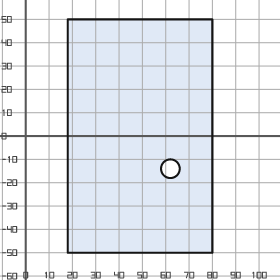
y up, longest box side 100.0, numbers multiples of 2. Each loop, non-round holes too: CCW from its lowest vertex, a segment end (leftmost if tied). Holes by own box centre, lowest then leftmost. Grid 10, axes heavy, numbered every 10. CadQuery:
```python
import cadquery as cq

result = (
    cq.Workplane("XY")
    .moveTo(18.0, -50.0)
    .lineTo(80.0, -50.0)
    .lineTo(80.0, 50.0)
    .lineTo(18.0, 50.0)
    .close()
    .moveTo(62.0, -14.0)
    .circle(4.0)
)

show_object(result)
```